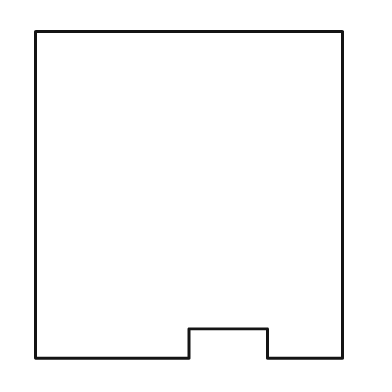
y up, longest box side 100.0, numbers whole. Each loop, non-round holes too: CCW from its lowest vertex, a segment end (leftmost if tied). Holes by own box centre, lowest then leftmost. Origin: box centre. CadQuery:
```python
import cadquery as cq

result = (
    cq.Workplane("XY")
    .moveTo(-47.0, -50.0)
    .lineTo(0.0, -50.0)
    .lineTo(0.0, -41.0)
    .lineTo(24.0, -41.0)
    .lineTo(24.0, -50.0)
    .lineTo(47.0, -50.0)
    .lineTo(47.0, 50.0)
    .lineTo(-47.0, 50.0)
    .close()
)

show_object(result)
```